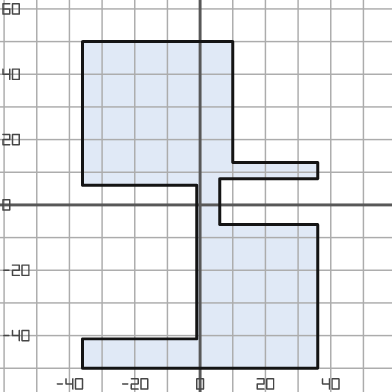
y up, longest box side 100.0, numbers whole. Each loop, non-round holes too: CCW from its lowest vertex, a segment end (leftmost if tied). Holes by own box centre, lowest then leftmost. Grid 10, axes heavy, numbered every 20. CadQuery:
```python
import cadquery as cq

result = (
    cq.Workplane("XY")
    .moveTo(-36.0, -50.0)
    .lineTo(36.0, -50.0)
    .lineTo(36.0, -6.0)
    .lineTo(6.0, -6.0)
    .lineTo(6.0, 8.0)
    .lineTo(36.0, 8.0)
    .lineTo(36.0, 13.0)
    .lineTo(10.0, 13.0)
    .lineTo(10.0, 50.0)
    .lineTo(-36.0, 50.0)
    .lineTo(-36.0, 6.0)
    .lineTo(-1.0, 6.0)
    .lineTo(-1.0, -41.0)
    .lineTo(-36.0, -41.0)
    .close()
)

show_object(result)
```